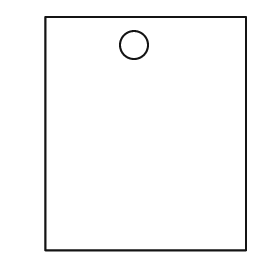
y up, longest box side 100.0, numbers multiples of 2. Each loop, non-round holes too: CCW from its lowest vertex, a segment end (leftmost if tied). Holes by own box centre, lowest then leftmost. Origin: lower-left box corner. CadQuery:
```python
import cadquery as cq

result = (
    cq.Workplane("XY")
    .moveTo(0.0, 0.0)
    .lineTo(86.0, 0.0)
    .lineTo(86.0, 100.0)
    .lineTo(0.0, 100.0)
    .close()
    .moveTo(38.0, 88.0)
    .circle(6.0)
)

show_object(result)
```